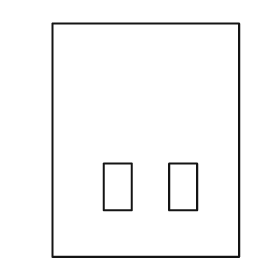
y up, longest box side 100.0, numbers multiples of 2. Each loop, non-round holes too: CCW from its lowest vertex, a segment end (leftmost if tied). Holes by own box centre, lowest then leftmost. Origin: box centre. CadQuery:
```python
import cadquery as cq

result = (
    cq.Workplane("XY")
    .moveTo(-40.0, -50.0)
    .lineTo(40.0, -50.0)
    .lineTo(40.0, 50.0)
    .lineTo(-40.0, 50.0)
    .close()
    .moveTo(-18.0, -30.0)
    .lineTo(-6.0, -30.0)
    .lineTo(-6.0, -10.0)
    .lineTo(-18.0, -10.0)
    .close()
    .moveTo(10.0, -30.0)
    .lineTo(22.0, -30.0)
    .lineTo(22.0, -10.0)
    .lineTo(10.0, -10.0)
    .close()
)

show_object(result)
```